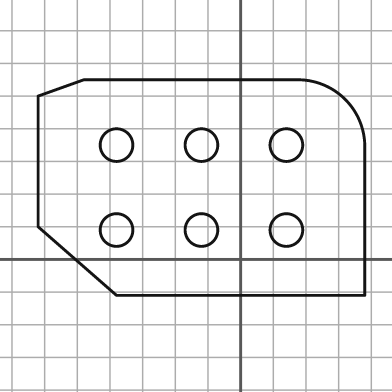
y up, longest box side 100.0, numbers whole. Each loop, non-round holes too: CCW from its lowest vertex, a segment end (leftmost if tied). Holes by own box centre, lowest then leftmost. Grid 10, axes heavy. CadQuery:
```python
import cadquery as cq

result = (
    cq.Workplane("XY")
    .moveTo(-38.0, -11.0)
    .lineTo(38.0, -11.0)
    .lineTo(38.0, 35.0)
    .threePointArc((32.0, 49.0), (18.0, 55.0))
    .lineTo(-48.0, 55.0)
    .lineTo(-62.0, 50.0)
    .lineTo(-62.0, 10.0)
    .close()
    .moveTo(-38.0, 9.0)
    .circle(5.0)
    .moveTo(-12.0, 9.0)
    .circle(5.0)
    .moveTo(14.0, 9.0)
    .circle(5.0)
    .moveTo(-38.0, 35.0)
    .circle(5.0)
    .moveTo(-12.0, 35.0)
    .circle(5.0)
    .moveTo(14.0, 35.0)
    .circle(5.0)
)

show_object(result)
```